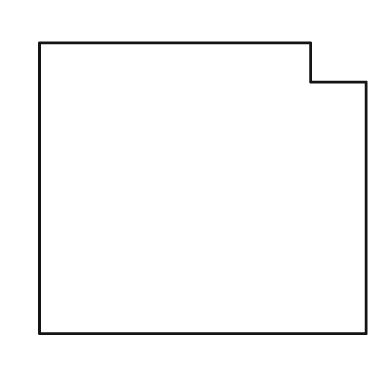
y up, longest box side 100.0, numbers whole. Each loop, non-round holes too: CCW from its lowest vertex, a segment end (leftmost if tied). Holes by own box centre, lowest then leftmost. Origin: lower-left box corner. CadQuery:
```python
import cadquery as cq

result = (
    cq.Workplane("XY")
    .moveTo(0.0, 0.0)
    .lineTo(100.0, 0.0)
    .lineTo(100.0, 77.0)
    .lineTo(83.0, 77.0)
    .lineTo(83.0, 89.0)
    .lineTo(0.0, 89.0)
    .close()
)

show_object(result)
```